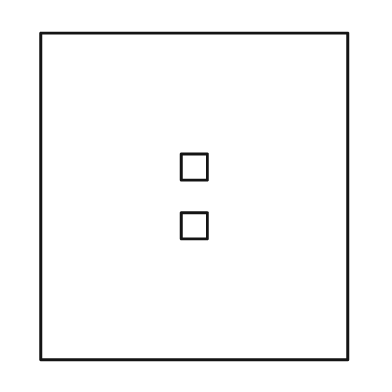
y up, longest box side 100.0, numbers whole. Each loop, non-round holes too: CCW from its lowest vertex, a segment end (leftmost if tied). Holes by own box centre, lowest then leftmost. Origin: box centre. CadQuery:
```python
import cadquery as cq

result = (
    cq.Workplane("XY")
    .moveTo(-47.0, -50.0)
    .lineTo(47.0, -50.0)
    .lineTo(47.0, 50.0)
    .lineTo(-47.0, 50.0)
    .close()
    .moveTo(-4.0, -13.0)
    .lineTo(4.0, -13.0)
    .lineTo(4.0, -5.0)
    .lineTo(-4.0, -5.0)
    .close()
    .moveTo(-4.0, 5.0)
    .lineTo(4.0, 5.0)
    .lineTo(4.0, 13.0)
    .lineTo(-4.0, 13.0)
    .close()
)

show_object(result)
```